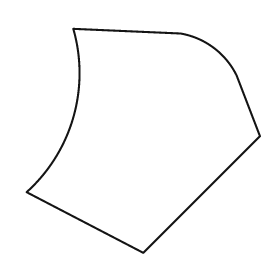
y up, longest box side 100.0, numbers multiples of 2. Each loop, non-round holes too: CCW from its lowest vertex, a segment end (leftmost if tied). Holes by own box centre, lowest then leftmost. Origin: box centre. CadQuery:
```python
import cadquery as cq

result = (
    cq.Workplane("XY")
    .moveTo(0.0, -48.0)
    .lineTo(50.0, 2.0)
    .lineTo(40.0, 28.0)
    .threePointArc((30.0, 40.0), (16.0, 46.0))
    .lineTo(-30.0, 48.0)
    .threePointArc((-30.0, 10.0), (-50.0, -22.0))
    .close()
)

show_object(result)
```